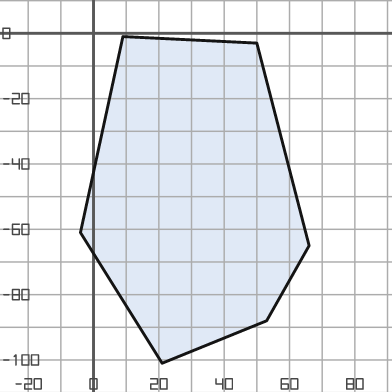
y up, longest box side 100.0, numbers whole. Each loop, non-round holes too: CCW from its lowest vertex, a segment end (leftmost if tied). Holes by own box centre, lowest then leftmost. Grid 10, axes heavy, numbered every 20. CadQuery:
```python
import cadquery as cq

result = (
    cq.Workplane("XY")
    .moveTo(21.0, -101.0)
    .lineTo(53.0, -88.0)
    .lineTo(66.0, -65.0)
    .lineTo(50.0, -3.0)
    .lineTo(9.0, -1.0)
    .lineTo(-4.0, -61.0)
    .close()
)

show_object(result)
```